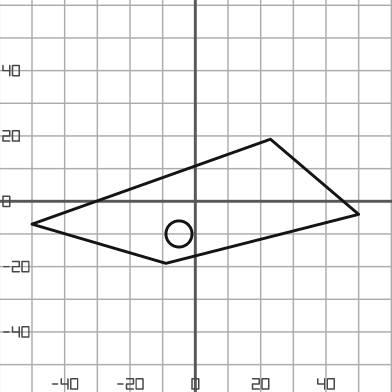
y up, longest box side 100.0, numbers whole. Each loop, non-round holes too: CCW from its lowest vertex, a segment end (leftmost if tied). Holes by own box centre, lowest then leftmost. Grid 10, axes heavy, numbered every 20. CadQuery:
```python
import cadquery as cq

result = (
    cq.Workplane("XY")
    .moveTo(-9.0, -19.0)
    .lineTo(50.0, -4.0)
    .lineTo(23.0, 19.0)
    .lineTo(-50.0, -7.0)
    .close()
    .moveTo(-5.0, -10.0)
    .circle(4.0)
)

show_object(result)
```